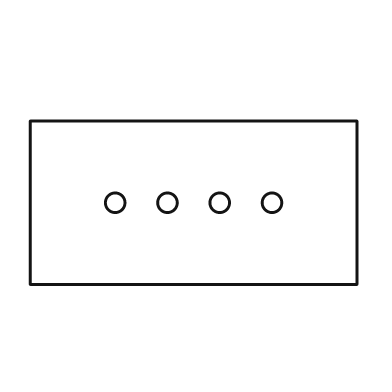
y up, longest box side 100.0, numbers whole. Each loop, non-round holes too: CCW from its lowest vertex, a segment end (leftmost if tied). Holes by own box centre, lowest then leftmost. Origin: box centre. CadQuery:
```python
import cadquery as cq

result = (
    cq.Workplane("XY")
    .moveTo(-50.0, -25.0)
    .lineTo(50.0, -25.0)
    .lineTo(50.0, 25.0)
    .lineTo(-50.0, 25.0)
    .close()
    .moveTo(-24.0, 0.0)
    .circle(3.0)
    .moveTo(-8.0, 0.0)
    .circle(3.0)
    .moveTo(8.0, 0.0)
    .circle(3.0)
    .moveTo(24.0, 0.0)
    .circle(3.0)
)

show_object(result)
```